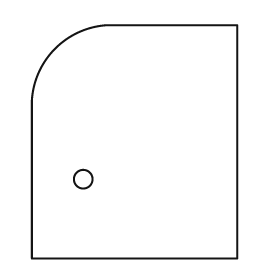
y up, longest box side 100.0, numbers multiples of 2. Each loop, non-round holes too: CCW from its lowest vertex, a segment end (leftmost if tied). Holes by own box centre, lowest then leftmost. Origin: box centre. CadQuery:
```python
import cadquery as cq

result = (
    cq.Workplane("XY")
    .moveTo(-44.0, -50.0)
    .lineTo(44.0, -50.0)
    .lineTo(44.0, 50.0)
    .lineTo(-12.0, 50.0)
    .threePointArc((-34.0, 40.0), (-44.0, 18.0))
    .close()
    .moveTo(-22.0, -16.0)
    .circle(4.0)
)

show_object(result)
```